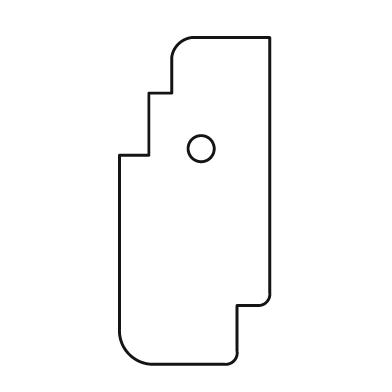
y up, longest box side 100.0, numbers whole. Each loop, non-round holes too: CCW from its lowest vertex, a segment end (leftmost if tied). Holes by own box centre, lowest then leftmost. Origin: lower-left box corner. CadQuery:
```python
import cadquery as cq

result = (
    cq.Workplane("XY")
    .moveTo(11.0, 0.0)
    .lineTo(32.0, 0.0)
    .threePointArc((35.0, 1.0), (36.0, 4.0))
    .lineTo(36.0, 18.0)
    .lineTo(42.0, 18.0)
    .threePointArc((45.0, 19.0), (46.0, 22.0))
    .lineTo(46.0, 100.0)
    .lineTo(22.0, 100.0)
    .threePointArc((18.0, 98.0), (16.0, 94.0))
    .lineTo(16.0, 83.0)
    .lineTo(9.0, 83.0)
    .lineTo(9.0, 64.0)
    .lineTo(0.0, 64.0)
    .lineTo(0.0, 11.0)
    .threePointArc((3.0, 3.0), (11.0, 0.0))
    .close()
    .moveTo(25.0, 66.0)
    .circle(4.0)
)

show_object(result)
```